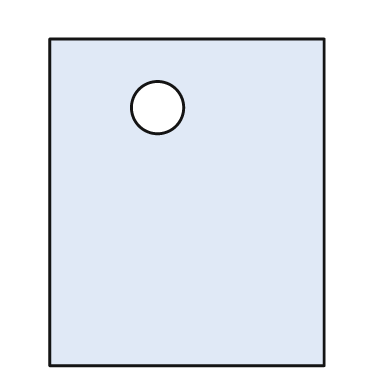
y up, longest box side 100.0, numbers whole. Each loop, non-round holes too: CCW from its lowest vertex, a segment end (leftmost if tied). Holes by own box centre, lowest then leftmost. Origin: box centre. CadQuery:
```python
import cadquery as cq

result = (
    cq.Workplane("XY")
    .moveTo(-42.0, -50.0)
    .lineTo(42.0, -50.0)
    .lineTo(42.0, 50.0)
    .lineTo(-42.0, 50.0)
    .close()
    .moveTo(-9.0, 29.0)
    .circle(8.0)
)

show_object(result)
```